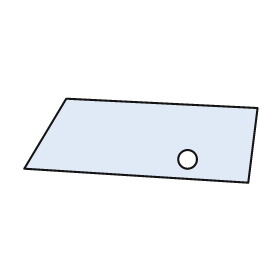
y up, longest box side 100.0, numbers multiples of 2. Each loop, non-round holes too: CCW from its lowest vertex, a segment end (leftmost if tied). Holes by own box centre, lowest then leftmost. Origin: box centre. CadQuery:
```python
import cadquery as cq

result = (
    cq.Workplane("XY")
    .moveTo(46.0, -18.0)
    .lineTo(50.0, 14.0)
    .lineTo(-32.0, 18.0)
    .lineTo(-50.0, -12.0)
    .close()
    .moveTo(20.0, -8.0)
    .circle(4.0)
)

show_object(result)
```